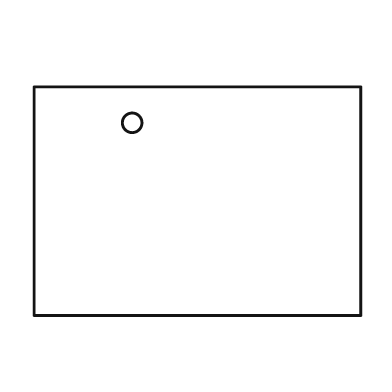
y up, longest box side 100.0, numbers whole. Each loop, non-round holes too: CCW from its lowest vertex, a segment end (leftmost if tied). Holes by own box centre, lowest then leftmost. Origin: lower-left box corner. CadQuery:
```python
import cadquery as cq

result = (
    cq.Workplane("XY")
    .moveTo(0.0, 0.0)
    .lineTo(100.0, 0.0)
    .lineTo(100.0, 70.0)
    .lineTo(0.0, 70.0)
    .close()
    .moveTo(30.0, 59.0)
    .circle(3.0)
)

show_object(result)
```